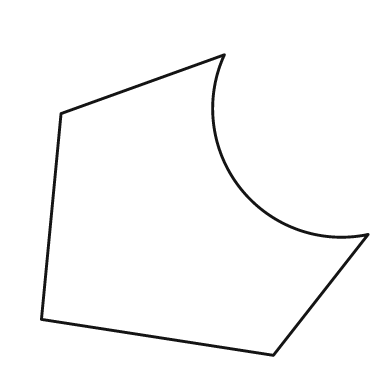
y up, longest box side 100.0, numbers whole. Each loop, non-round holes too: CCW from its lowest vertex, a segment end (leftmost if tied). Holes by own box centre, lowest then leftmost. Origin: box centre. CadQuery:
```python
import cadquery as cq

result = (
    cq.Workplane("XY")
    .moveTo(21.0, -46.0)
    .lineTo(50.0, -9.0)
    .threePointArc((11.0, 5.0), (6.0, 46.0))
    .lineTo(-44.0, 28.0)
    .lineTo(-50.0, -35.0)
    .close()
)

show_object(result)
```